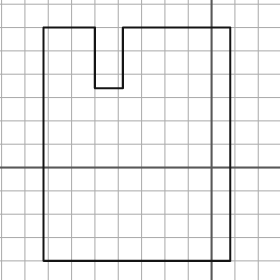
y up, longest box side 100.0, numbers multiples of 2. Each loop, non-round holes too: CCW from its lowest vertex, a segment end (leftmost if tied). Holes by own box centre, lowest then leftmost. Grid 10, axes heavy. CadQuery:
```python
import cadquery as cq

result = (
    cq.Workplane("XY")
    .moveTo(-72.0, -40.0)
    .lineTo(8.0, -40.0)
    .lineTo(8.0, 60.0)
    .lineTo(-38.0, 60.0)
    .lineTo(-38.0, 34.0)
    .lineTo(-50.0, 34.0)
    .lineTo(-50.0, 60.0)
    .lineTo(-72.0, 60.0)
    .close()
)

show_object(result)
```